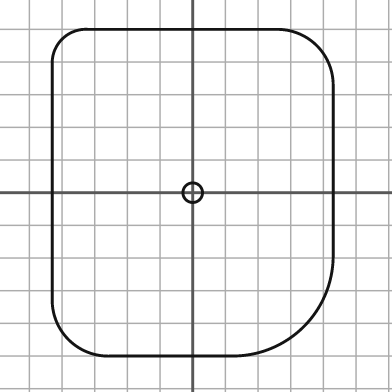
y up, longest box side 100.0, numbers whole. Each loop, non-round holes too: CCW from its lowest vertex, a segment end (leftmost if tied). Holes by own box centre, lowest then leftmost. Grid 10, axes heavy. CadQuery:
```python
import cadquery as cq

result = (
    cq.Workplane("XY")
    .moveTo(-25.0, -50.0)
    .lineTo(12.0, -50.0)
    .threePointArc((34.0, -41.0), (43.0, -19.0))
    .lineTo(43.0, 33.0)
    .threePointArc((38.0, 45.0), (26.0, 50.0))
    .lineTo(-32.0, 50.0)
    .threePointArc((-40.0, 47.0), (-43.0, 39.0))
    .lineTo(-43.0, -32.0)
    .threePointArc((-38.0, -45.0), (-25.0, -50.0))
    .close()
    .moveTo(0.0, 0.0)
    .circle(3.0)
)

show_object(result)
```